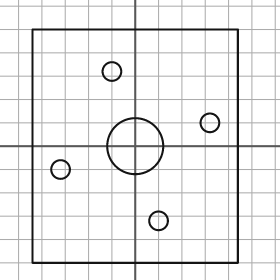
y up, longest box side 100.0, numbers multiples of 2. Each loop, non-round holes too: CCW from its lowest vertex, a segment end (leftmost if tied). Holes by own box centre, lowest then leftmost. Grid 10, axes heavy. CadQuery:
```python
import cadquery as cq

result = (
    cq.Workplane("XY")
    .moveTo(-44.0, -50.0)
    .lineTo(44.0, -50.0)
    .lineTo(44.0, 50.0)
    .lineTo(-44.0, 50.0)
    .close()
    .moveTo(10.0, -32.0)
    .circle(4.0)
    .moveTo(-32.0, -10.0)
    .circle(4.0)
    .moveTo(0.0, 0.0)
    .circle(12.0)
    .moveTo(32.0, 10.0)
    .circle(4.0)
    .moveTo(-10.0, 32.0)
    .circle(4.0)
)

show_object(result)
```